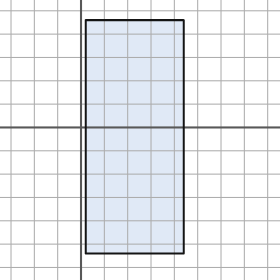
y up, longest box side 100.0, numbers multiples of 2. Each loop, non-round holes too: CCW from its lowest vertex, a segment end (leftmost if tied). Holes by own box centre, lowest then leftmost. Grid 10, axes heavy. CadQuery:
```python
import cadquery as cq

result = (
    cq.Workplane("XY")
    .moveTo(2.0, -54.0)
    .lineTo(44.0, -54.0)
    .lineTo(44.0, 46.0)
    .lineTo(2.0, 46.0)
    .close()
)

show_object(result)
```